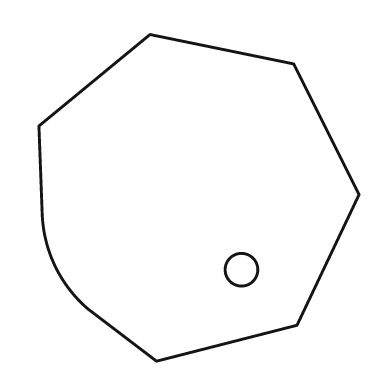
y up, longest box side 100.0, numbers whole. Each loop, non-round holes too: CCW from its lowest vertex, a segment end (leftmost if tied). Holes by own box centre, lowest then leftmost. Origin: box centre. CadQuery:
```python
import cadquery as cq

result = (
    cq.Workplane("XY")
    .moveTo(-13.0, -50.0)
    .lineTo(30.0, -39.0)
    .lineTo(49.0, 1.0)
    .lineTo(29.0, 41.0)
    .lineTo(-15.0, 50.0)
    .lineTo(-49.0, 22.0)
    .lineTo(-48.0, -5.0)
    .threePointArc((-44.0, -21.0), (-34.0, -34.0))
    .close()
    .moveTo(13.0, -22.0)
    .circle(5.0)
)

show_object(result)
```